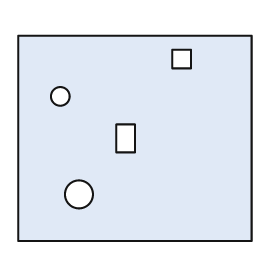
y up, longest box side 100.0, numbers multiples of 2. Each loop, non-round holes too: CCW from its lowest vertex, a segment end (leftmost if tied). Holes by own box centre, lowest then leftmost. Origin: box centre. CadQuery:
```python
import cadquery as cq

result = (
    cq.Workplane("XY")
    .moveTo(-50.0, -44.0)
    .lineTo(50.0, -44.0)
    .lineTo(50.0, 44.0)
    .lineTo(-50.0, 44.0)
    .close()
    .moveTo(-24.0, -24.0)
    .circle(6.0)
    .moveTo(-8.0, -6.0)
    .lineTo(0.0, -6.0)
    .lineTo(0.0, 6.0)
    .lineTo(-8.0, 6.0)
    .close()
    .moveTo(-32.0, 18.0)
    .circle(4.0)
    .moveTo(16.0, 30.0)
    .lineTo(24.0, 30.0)
    .lineTo(24.0, 38.0)
    .lineTo(16.0, 38.0)
    .close()
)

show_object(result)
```